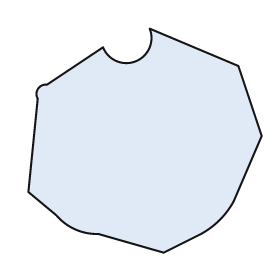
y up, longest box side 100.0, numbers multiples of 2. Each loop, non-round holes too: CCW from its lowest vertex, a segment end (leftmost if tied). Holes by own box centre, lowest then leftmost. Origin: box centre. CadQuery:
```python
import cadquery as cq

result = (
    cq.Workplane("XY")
    .moveTo(8.0, -48.0)
    .lineTo(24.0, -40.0)
    .threePointArc((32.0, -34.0), (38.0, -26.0))
    .lineTo(50.0, 2.0)
    .lineTo(40.0, 32.0)
    .lineTo(2.0, 48.0)
    .threePointArc((-4.0, 34.0), (-18.0, 40.0))
    .lineTo(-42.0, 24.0)
    .threePointArc((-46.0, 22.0), (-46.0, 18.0))
    .lineTo(-50.0, -22.0)
    .lineTo(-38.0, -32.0)
    .threePointArc((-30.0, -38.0), (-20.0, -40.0))
    .close()
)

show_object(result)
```